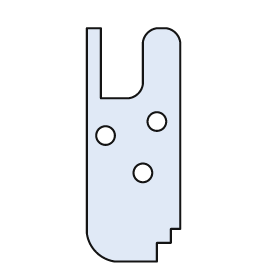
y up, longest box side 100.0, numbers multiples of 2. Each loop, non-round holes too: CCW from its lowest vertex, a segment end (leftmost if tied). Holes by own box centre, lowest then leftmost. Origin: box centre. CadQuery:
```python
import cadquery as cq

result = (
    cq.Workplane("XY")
    .moveTo(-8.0, -50.0)
    .lineTo(10.0, -50.0)
    .lineTo(10.0, -42.0)
    .lineTo(16.0, -42.0)
    .lineTo(16.0, -36.0)
    .lineTo(20.0, -36.0)
    .lineTo(20.0, 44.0)
    .threePointArc((18.0, 48.0), (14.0, 50.0))
    .lineTo(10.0, 50.0)
    .threePointArc((6.0, 48.0), (4.0, 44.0))
    .lineTo(4.0, 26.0)
    .threePointArc((2.0, 22.0), (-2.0, 20.0))
    .lineTo(-14.0, 20.0)
    .lineTo(-14.0, 50.0)
    .lineTo(-20.0, 50.0)
    .lineTo(-20.0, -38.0)
    .threePointArc((-16.0, -46.0), (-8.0, -50.0))
    .close()
    .moveTo(4.0, -12.0)
    .circle(4.0)
    .moveTo(-12.0, 4.0)
    .circle(4.0)
    .moveTo(10.0, 10.0)
    .circle(4.0)
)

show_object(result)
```